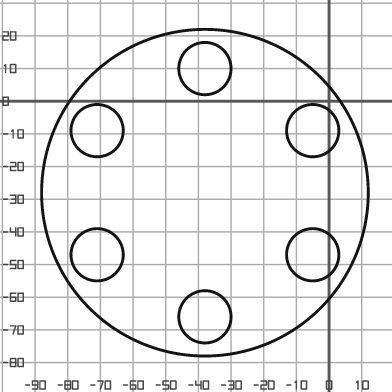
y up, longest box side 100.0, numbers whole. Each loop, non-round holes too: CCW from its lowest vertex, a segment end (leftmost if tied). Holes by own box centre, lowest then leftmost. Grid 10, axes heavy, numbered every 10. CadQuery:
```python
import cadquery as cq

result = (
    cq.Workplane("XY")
    .moveTo(-38.0, -28.0)
    .circle(50.0)
    .moveTo(-38.0, -66.0)
    .circle(8.0)
    .moveTo(-71.0, -47.0)
    .circle(8.0)
    .moveTo(-5.0, -47.0)
    .circle(8.0)
    .moveTo(-71.0, -9.0)
    .circle(8.0)
    .moveTo(-5.0, -9.0)
    .circle(8.0)
    .moveTo(-38.0, 10.0)
    .circle(8.0)
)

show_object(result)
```